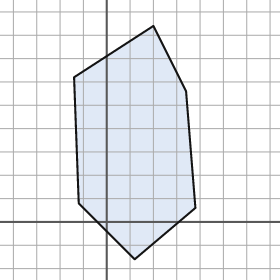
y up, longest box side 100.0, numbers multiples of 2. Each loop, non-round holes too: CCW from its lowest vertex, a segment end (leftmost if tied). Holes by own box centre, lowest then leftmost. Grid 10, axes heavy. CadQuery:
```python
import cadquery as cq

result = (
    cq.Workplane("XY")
    .moveTo(12.0, -16.0)
    .lineTo(38.0, 6.0)
    .lineTo(34.0, 56.0)
    .lineTo(20.0, 84.0)
    .lineTo(-14.0, 62.0)
    .lineTo(-12.0, 8.0)
    .close()
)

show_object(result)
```